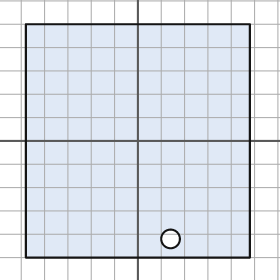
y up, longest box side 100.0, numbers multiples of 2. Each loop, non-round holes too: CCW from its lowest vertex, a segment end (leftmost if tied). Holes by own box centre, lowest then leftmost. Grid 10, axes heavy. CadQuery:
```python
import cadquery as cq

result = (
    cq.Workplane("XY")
    .moveTo(-48.0, -50.0)
    .lineTo(48.0, -50.0)
    .lineTo(48.0, 50.0)
    .lineTo(-48.0, 50.0)
    .close()
    .moveTo(14.0, -42.0)
    .circle(4.0)
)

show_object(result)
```